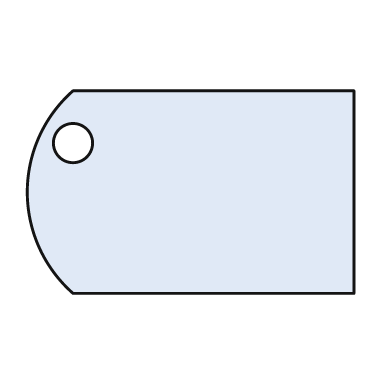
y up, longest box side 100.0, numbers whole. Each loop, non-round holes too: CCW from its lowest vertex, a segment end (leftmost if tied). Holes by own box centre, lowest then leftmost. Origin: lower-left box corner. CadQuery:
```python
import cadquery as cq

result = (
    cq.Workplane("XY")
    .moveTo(14.0, 0.0)
    .lineTo(100.0, 0.0)
    .lineTo(100.0, 62.0)
    .lineTo(14.0, 62.0)
    .threePointArc((0.0, 31.0), (14.0, 0.0))
    .close()
    .moveTo(14.0, 46.0)
    .circle(6.0)
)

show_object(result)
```